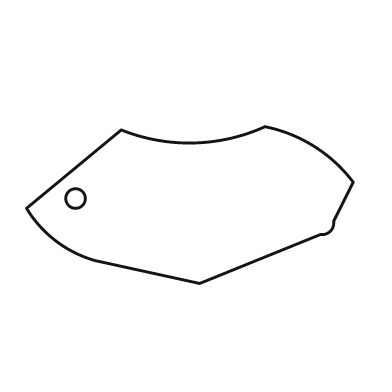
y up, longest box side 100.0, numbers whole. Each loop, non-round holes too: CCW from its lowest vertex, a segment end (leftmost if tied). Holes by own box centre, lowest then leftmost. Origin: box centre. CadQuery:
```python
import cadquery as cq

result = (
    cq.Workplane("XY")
    .moveTo(3.0, -24.0)
    .lineTo(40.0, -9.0)
    .threePointArc((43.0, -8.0), (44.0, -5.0))
    .lineTo(50.0, 7.0)
    .threePointArc((38.0, 18.0), (23.0, 24.0))
    .threePointArc((1.0, 19.0), (-21.0, 23.0))
    .lineTo(-50.0, -1.0)
    .threePointArc((-41.0, -11.0), (-29.0, -17.0))
    .close()
    .moveTo(-35.0, 2.0)
    .circle(3.0)
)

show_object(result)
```